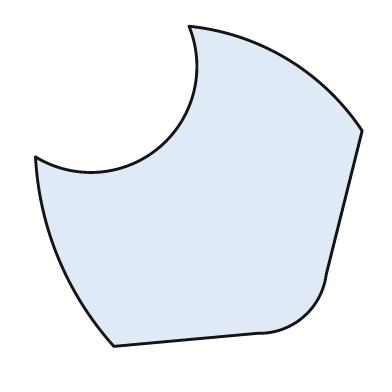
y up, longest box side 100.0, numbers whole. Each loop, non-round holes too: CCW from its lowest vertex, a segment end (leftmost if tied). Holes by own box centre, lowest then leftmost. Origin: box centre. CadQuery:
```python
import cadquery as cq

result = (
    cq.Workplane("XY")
    .moveTo(-26.0, -49.0)
    .lineTo(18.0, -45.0)
    .threePointArc((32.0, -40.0), (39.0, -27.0))
    .lineTo(50.0, 17.0)
    .threePointArc((27.0, 39.0), (-3.0, 49.0))
    .threePointArc((-12.0, 12.0), (-50.0, 9.0))
    .threePointArc((-43.0, -22.0), (-26.0, -49.0))
    .close()
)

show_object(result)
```